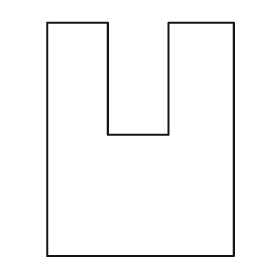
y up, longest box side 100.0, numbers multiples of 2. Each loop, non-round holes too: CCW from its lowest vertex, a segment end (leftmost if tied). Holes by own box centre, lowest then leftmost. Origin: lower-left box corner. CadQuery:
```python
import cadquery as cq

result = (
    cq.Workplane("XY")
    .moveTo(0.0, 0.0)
    .lineTo(80.0, 0.0)
    .lineTo(80.0, 100.0)
    .lineTo(52.0, 100.0)
    .lineTo(52.0, 52.0)
    .lineTo(26.0, 52.0)
    .lineTo(26.0, 100.0)
    .lineTo(0.0, 100.0)
    .close()
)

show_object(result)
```